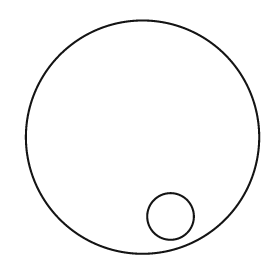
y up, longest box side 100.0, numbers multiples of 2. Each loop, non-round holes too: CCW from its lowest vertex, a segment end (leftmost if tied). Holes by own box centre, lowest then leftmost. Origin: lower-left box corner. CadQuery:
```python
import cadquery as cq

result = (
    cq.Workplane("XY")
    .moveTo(50.0, 50.0)
    .circle(50.0)
    .moveTo(62.0, 16.0)
    .circle(10.0)
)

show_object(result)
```